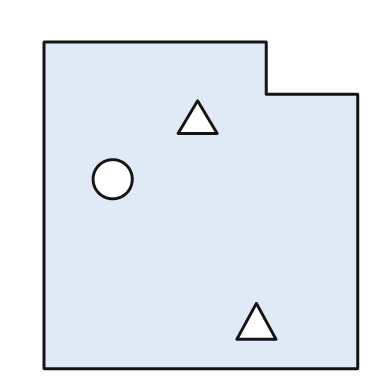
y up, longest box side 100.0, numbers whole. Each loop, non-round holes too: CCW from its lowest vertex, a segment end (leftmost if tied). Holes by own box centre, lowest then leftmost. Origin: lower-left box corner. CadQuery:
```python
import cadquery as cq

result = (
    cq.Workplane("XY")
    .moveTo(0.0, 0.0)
    .lineTo(96.0, 0.0)
    .lineTo(96.0, 84.0)
    .lineTo(68.0, 84.0)
    .lineTo(68.0, 100.0)
    .lineTo(0.0, 100.0)
    .close()
    .moveTo(59.0, 9.0)
    .lineTo(71.0, 9.0)
    .lineTo(65.0, 20.0)
    .close()
    .moveTo(21.0, 58.0)
    .circle(6.0)
    .moveTo(41.0, 72.0)
    .lineTo(53.0, 72.0)
    .lineTo(47.0, 82.0)
    .close()
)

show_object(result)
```